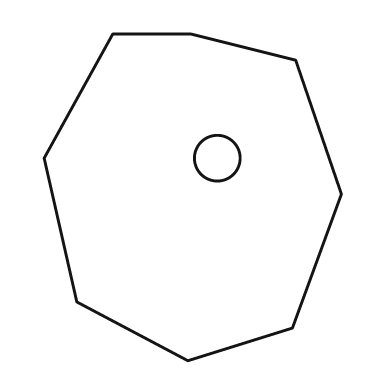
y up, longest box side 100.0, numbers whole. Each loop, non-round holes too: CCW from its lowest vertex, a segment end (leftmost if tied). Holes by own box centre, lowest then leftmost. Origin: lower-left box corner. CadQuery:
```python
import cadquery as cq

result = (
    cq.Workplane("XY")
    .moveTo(44.0, 0.0)
    .lineTo(76.0, 10.0)
    .lineTo(91.0, 51.0)
    .lineTo(77.0, 92.0)
    .lineTo(45.0, 100.0)
    .lineTo(21.0, 100.0)
    .lineTo(0.0, 62.0)
    .lineTo(10.0, 18.0)
    .close()
    .moveTo(53.0, 62.0)
    .circle(7.0)
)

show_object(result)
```